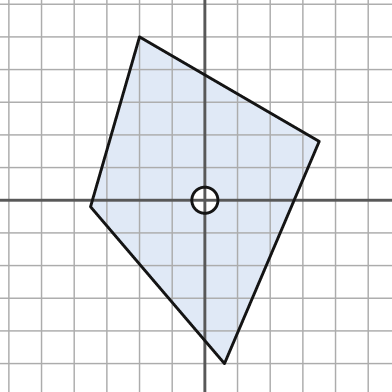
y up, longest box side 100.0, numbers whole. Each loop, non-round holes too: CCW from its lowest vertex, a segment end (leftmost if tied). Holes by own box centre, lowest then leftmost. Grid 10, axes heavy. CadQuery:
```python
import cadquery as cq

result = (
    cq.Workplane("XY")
    .moveTo(6.0, -50.0)
    .lineTo(35.0, 18.0)
    .lineTo(-20.0, 50.0)
    .lineTo(-35.0, -2.0)
    .close()
    .moveTo(0.0, 0.0)
    .circle(4.0)
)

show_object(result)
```